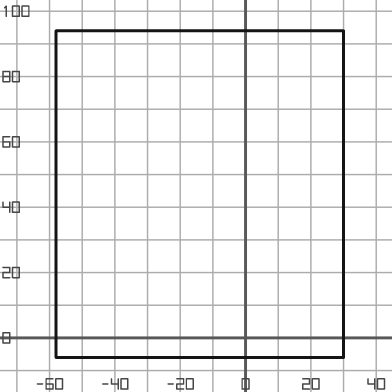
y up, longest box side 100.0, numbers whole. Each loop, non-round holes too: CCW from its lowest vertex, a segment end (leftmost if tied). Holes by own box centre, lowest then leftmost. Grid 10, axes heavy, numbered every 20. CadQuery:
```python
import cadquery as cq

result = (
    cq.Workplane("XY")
    .moveTo(-58.0, -6.0)
    .lineTo(30.0, -6.0)
    .lineTo(30.0, 94.0)
    .lineTo(-58.0, 94.0)
    .close()
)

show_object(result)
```